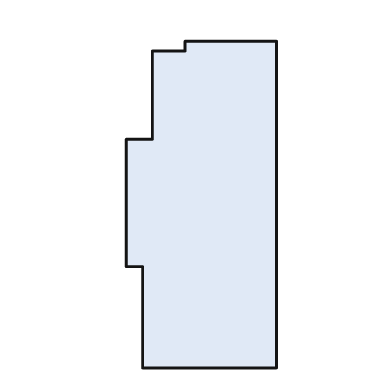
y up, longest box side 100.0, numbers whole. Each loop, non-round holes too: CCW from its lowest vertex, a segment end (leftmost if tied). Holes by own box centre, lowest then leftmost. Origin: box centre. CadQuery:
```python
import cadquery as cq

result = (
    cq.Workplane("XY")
    .moveTo(-18.0, -50.0)
    .lineTo(23.0, -50.0)
    .lineTo(23.0, 50.0)
    .lineTo(-5.0, 50.0)
    .lineTo(-5.0, 47.0)
    .lineTo(-15.0, 47.0)
    .lineTo(-15.0, 20.0)
    .lineTo(-23.0, 20.0)
    .lineTo(-23.0, -19.0)
    .lineTo(-18.0, -19.0)
    .close()
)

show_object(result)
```